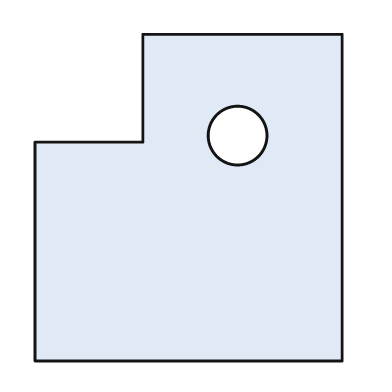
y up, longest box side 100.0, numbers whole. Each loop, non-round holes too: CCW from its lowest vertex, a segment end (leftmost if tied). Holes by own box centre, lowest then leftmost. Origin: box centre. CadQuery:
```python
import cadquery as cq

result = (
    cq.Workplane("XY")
    .moveTo(-47.0, -50.0)
    .lineTo(47.0, -50.0)
    .lineTo(47.0, 50.0)
    .lineTo(-14.0, 50.0)
    .lineTo(-14.0, 17.0)
    .lineTo(-47.0, 17.0)
    .close()
    .moveTo(15.0, 19.0)
    .circle(9.0)
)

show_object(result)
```